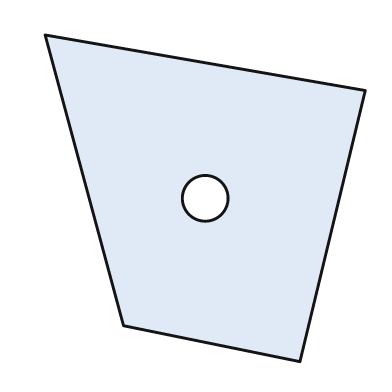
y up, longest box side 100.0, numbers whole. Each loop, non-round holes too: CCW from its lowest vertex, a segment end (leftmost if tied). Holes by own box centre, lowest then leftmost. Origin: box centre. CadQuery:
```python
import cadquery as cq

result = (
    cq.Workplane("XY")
    .moveTo(29.0, -50.0)
    .lineTo(49.0, 33.0)
    .lineTo(-49.0, 50.0)
    .lineTo(-25.0, -39.0)
    .close()
    .moveTo(0.0, 0.0)
    .circle(7.0)
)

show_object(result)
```